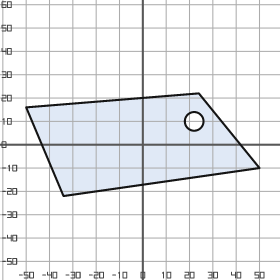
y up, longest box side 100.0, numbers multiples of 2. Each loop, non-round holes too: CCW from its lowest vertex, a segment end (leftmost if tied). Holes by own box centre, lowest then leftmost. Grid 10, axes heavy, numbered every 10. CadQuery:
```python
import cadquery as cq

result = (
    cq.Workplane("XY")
    .moveTo(-34.0, -22.0)
    .lineTo(50.0, -10.0)
    .lineTo(24.0, 22.0)
    .lineTo(-50.0, 16.0)
    .close()
    .moveTo(22.0, 10.0)
    .circle(4.0)
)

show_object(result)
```